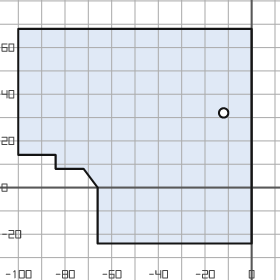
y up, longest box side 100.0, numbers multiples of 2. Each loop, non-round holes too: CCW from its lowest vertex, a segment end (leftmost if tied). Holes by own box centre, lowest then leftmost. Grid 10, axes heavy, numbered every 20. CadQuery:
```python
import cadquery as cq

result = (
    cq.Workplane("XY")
    .moveTo(-66.0, -24.0)
    .lineTo(0.0, -24.0)
    .lineTo(0.0, 68.0)
    .lineTo(-100.0, 68.0)
    .lineTo(-100.0, 14.0)
    .lineTo(-84.0, 14.0)
    .lineTo(-84.0, 8.0)
    .lineTo(-72.0, 8.0)
    .lineTo(-66.0, 0.0)
    .close()
    .moveTo(-12.0, 32.0)
    .circle(2.0)
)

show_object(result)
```